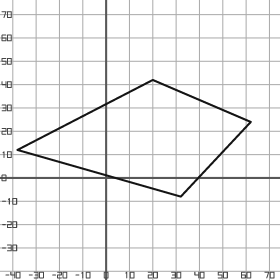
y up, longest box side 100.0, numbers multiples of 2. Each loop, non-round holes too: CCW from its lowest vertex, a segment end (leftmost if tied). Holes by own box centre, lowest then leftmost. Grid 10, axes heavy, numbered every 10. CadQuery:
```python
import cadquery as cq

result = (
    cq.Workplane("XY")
    .moveTo(32.0, -8.0)
    .lineTo(62.0, 24.0)
    .lineTo(20.0, 42.0)
    .lineTo(-38.0, 12.0)
    .close()
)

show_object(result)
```